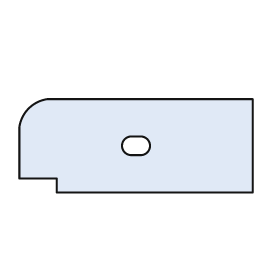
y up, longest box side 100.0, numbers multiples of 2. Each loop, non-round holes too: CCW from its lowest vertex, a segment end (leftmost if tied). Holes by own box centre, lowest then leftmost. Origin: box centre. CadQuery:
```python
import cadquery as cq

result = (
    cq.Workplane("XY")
    .moveTo(-34.0, -20.0)
    .lineTo(50.0, -20.0)
    .lineTo(50.0, 20.0)
    .lineTo(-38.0, 20.0)
    .threePointArc((-46.0, 16.0), (-50.0, 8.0))
    .lineTo(-50.0, -14.0)
    .lineTo(-34.0, -14.0)
    .close()
    .moveTo(-2.0, -4.0)
    .lineTo(2.0, -4.0)
    .threePointArc((6.0, 0.0), (2.0, 4.0))
    .lineTo(-2.0, 4.0)
    .threePointArc((-6.0, 0.0), (-2.0, -4.0))
    .close()
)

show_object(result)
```